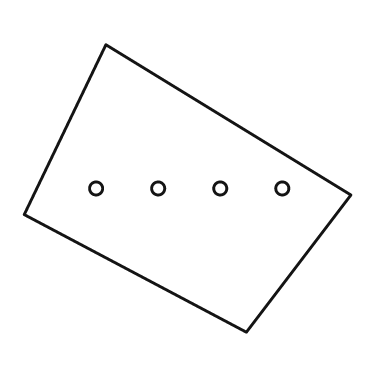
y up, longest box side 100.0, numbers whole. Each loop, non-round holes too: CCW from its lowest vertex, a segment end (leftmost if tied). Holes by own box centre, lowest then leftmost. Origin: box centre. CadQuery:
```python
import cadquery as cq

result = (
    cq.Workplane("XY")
    .moveTo(18.0, -44.0)
    .lineTo(50.0, -2.0)
    .lineTo(-25.0, 44.0)
    .lineTo(-50.0, -8.0)
    .close()
    .moveTo(-28.0, 0.0)
    .circle(2.0)
    .moveTo(-9.0, 0.0)
    .circle(2.0)
    .moveTo(10.0, 0.0)
    .circle(2.0)
    .moveTo(29.0, 0.0)
    .circle(2.0)
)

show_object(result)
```